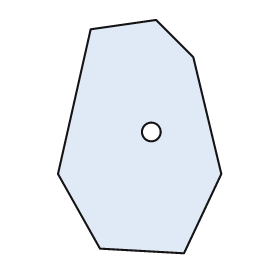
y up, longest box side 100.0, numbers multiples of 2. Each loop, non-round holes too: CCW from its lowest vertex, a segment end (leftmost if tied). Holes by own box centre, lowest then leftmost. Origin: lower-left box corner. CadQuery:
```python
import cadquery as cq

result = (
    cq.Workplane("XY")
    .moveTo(54.0, 0.0)
    .lineTo(70.0, 34.0)
    .lineTo(58.0, 84.0)
    .lineTo(42.0, 100.0)
    .lineTo(14.0, 96.0)
    .lineTo(0.0, 34.0)
    .lineTo(18.0, 2.0)
    .close()
    .moveTo(40.0, 52.0)
    .circle(4.0)
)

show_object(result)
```